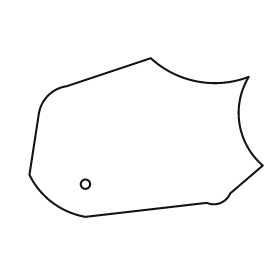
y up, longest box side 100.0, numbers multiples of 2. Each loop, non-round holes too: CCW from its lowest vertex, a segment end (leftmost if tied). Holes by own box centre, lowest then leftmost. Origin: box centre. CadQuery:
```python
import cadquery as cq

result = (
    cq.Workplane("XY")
    .moveTo(-26.0, -34.0)
    .lineTo(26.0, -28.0)
    .threePointArc((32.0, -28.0), (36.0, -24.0))
    .lineTo(50.0, -12.0)
    .threePointArc((40.0, 6.0), (44.0, 26.0))
    .threePointArc((22.0, 24.0), (2.0, 34.0))
    .lineTo(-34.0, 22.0)
    .threePointArc((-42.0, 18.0), (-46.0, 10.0))
    .lineTo(-50.0, -16.0)
    .threePointArc((-40.0, -28.0), (-26.0, -34.0))
    .close()
    .moveTo(-26.0, -20.0)
    .circle(2.0)
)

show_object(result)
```